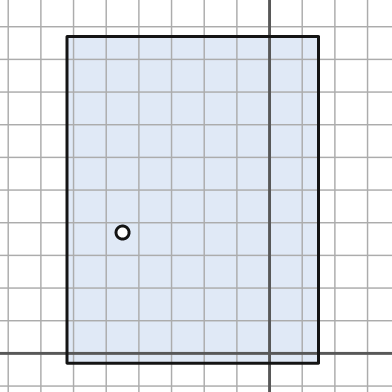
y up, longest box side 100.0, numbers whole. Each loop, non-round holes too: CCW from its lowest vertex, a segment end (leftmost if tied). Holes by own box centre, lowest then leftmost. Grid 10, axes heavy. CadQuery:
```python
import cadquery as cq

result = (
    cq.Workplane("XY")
    .moveTo(-62.0, -3.0)
    .lineTo(15.0, -3.0)
    .lineTo(15.0, 97.0)
    .lineTo(-62.0, 97.0)
    .close()
    .moveTo(-45.0, 37.0)
    .circle(2.0)
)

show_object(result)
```